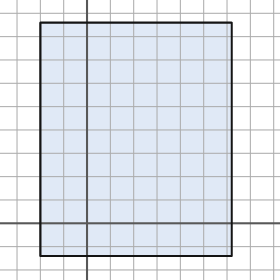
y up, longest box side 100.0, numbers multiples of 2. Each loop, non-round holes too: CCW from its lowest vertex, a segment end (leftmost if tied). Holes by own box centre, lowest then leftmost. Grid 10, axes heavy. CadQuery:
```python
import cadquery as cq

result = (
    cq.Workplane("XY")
    .moveTo(-20.0, -14.0)
    .lineTo(62.0, -14.0)
    .lineTo(62.0, 86.0)
    .lineTo(-20.0, 86.0)
    .close()
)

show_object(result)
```